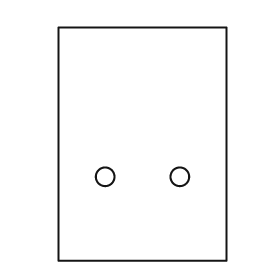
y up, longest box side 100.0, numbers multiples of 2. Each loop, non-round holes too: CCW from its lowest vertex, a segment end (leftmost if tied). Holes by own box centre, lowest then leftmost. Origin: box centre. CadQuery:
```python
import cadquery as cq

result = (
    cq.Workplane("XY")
    .moveTo(-36.0, -50.0)
    .lineTo(36.0, -50.0)
    .lineTo(36.0, 50.0)
    .lineTo(-36.0, 50.0)
    .close()
    .moveTo(-16.0, -14.0)
    .circle(4.0)
    .moveTo(16.0, -14.0)
    .circle(4.0)
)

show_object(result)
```